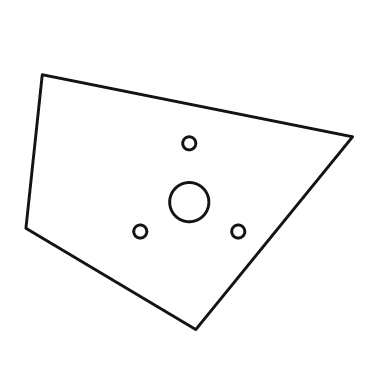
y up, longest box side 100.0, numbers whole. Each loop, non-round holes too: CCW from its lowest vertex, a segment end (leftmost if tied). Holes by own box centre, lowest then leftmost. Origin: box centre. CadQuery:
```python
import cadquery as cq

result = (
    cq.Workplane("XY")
    .moveTo(2.0, -39.0)
    .lineTo(50.0, 20.0)
    .lineTo(-45.0, 39.0)
    .lineTo(-50.0, -8.0)
    .close()
    .moveTo(-15.0, -9.0)
    .circle(2.0)
    .moveTo(15.0, -9.0)
    .circle(2.0)
    .moveTo(0.0, 0.0)
    .circle(6.0)
    .moveTo(0.0, 18.0)
    .circle(2.0)
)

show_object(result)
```